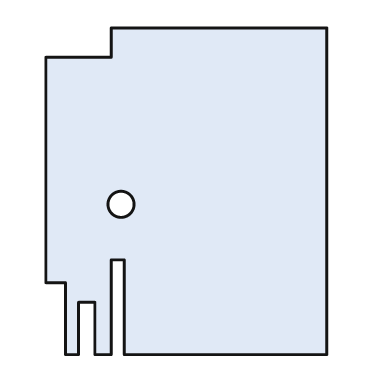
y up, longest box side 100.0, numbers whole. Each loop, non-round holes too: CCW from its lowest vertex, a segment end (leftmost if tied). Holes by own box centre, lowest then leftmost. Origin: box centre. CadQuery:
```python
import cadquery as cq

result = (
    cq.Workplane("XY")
    .moveTo(-37.0, -50.0)
    .lineTo(-33.0, -50.0)
    .lineTo(-33.0, -34.0)
    .lineTo(-28.0, -34.0)
    .lineTo(-28.0, -50.0)
    .lineTo(-23.0, -50.0)
    .lineTo(-23.0, -21.0)
    .lineTo(-19.0, -21.0)
    .lineTo(-19.0, -50.0)
    .lineTo(43.0, -50.0)
    .lineTo(43.0, 50.0)
    .lineTo(-23.0, 50.0)
    .lineTo(-23.0, 41.0)
    .lineTo(-43.0, 41.0)
    .lineTo(-43.0, -28.0)
    .lineTo(-37.0, -28.0)
    .close()
    .moveTo(-20.0, -4.0)
    .circle(4.0)
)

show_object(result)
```